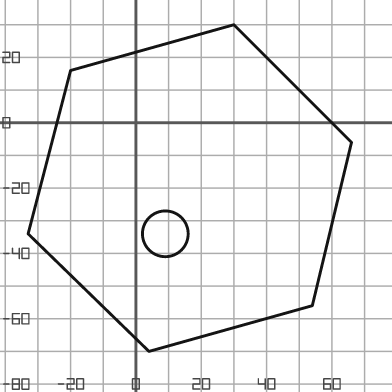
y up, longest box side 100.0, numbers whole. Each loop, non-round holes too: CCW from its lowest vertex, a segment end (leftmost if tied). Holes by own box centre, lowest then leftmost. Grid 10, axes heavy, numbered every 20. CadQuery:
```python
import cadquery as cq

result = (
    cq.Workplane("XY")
    .moveTo(4.0, -70.0)
    .lineTo(54.0, -56.0)
    .lineTo(66.0, -6.0)
    .lineTo(30.0, 30.0)
    .lineTo(-20.0, 16.0)
    .lineTo(-33.0, -34.0)
    .close()
    .moveTo(9.0, -34.0)
    .circle(7.0)
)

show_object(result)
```